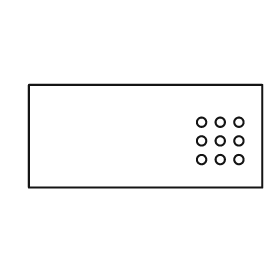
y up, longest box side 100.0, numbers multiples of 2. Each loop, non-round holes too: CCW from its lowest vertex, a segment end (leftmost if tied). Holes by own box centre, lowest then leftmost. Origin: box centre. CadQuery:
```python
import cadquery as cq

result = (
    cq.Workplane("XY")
    .moveTo(-50.0, -22.0)
    .lineTo(50.0, -22.0)
    .lineTo(50.0, 22.0)
    .lineTo(-50.0, 22.0)
    .close()
    .moveTo(24.0, -10.0)
    .circle(2.0)
    .moveTo(32.0, -10.0)
    .circle(2.0)
    .moveTo(40.0, -10.0)
    .circle(2.0)
    .moveTo(24.0, -2.0)
    .circle(2.0)
    .moveTo(32.0, -2.0)
    .circle(2.0)
    .moveTo(40.0, -2.0)
    .circle(2.0)
    .moveTo(24.0, 6.0)
    .circle(2.0)
    .moveTo(32.0, 6.0)
    .circle(2.0)
    .moveTo(40.0, 6.0)
    .circle(2.0)
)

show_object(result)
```